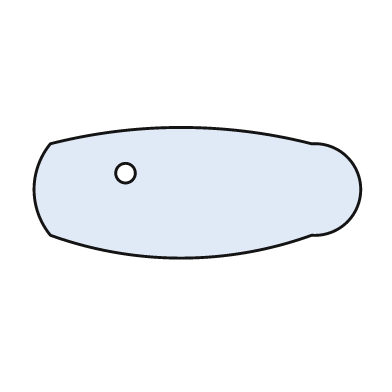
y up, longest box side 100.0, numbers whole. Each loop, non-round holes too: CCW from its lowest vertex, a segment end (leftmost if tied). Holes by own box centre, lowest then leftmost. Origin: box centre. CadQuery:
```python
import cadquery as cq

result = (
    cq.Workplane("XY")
    .moveTo(-45.0, -13.0)
    .threePointArc((-5.0, -20.0), (35.0, -13.0))
    .threePointArc((50.0, 1.0), (35.0, 15.0))
    .threePointArc((-5.0, 20.0), (-45.0, 15.0))
    .threePointArc((-50.0, 1.0), (-45.0, -13.0))
    .close()
    .moveTo(-22.0, 6.0)
    .circle(3.0)
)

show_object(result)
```